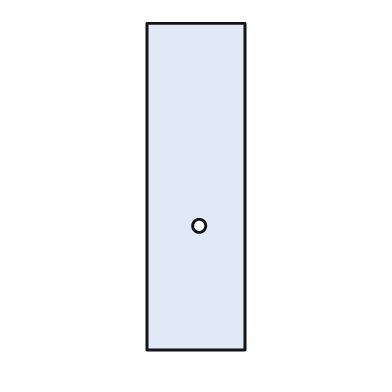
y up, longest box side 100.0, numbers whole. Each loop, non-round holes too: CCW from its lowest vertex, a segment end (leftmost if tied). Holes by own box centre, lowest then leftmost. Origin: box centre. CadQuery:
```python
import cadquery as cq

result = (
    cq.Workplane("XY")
    .moveTo(-15.0, -50.0)
    .lineTo(15.0, -50.0)
    .lineTo(15.0, 50.0)
    .lineTo(-15.0, 50.0)
    .close()
    .moveTo(1.0, -12.0)
    .circle(2.0)
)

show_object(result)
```